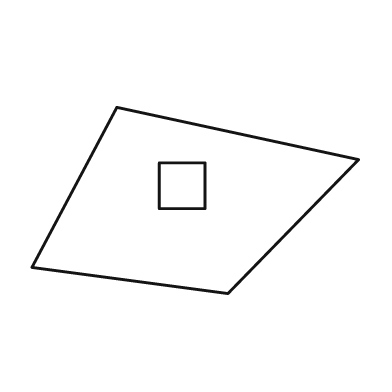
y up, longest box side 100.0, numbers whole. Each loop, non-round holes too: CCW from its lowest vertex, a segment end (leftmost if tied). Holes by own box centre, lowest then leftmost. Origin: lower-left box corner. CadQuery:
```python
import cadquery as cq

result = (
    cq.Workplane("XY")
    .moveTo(60.0, 0.0)
    .lineTo(100.0, 41.0)
    .lineTo(26.0, 57.0)
    .lineTo(0.0, 8.0)
    .close()
    .moveTo(39.0, 26.0)
    .lineTo(53.0, 26.0)
    .lineTo(53.0, 40.0)
    .lineTo(39.0, 40.0)
    .close()
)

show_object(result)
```